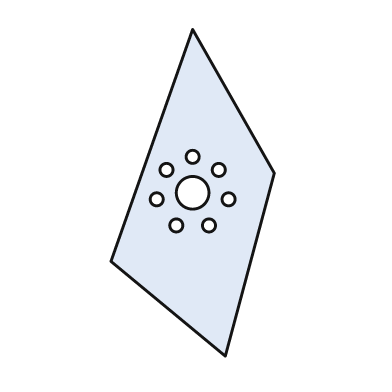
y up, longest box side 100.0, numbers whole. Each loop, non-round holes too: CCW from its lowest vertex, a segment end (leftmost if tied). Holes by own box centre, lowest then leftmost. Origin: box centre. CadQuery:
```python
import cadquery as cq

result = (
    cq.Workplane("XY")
    .moveTo(10.0, -50.0)
    .lineTo(25.0, 6.0)
    .lineTo(0.0, 50.0)
    .lineTo(-25.0, -21.0)
    .close()
    .moveTo(-5.0, -10.0)
    .circle(2.0)
    .moveTo(5.0, -10.0)
    .circle(2.0)
    .moveTo(-11.0, -2.0)
    .circle(2.0)
    .moveTo(11.0, -2.0)
    .circle(2.0)
    .moveTo(0.0, 0.0)
    .circle(5.0)
    .moveTo(-8.0, 7.0)
    .circle(2.0)
    .moveTo(8.0, 7.0)
    .circle(2.0)
    .moveTo(0.0, 11.0)
    .circle(2.0)
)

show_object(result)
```